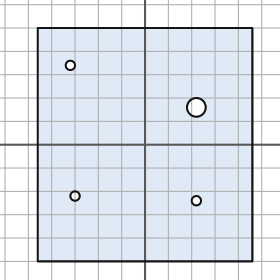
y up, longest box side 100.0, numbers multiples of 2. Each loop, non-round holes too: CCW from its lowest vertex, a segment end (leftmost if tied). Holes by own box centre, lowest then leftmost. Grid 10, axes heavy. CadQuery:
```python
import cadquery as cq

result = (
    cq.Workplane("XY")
    .moveTo(-46.0, -50.0)
    .lineTo(46.0, -50.0)
    .lineTo(46.0, 50.0)
    .lineTo(-46.0, 50.0)
    .close()
    .moveTo(22.0, -24.0)
    .circle(2.0)
    .moveTo(-30.0, -22.0)
    .circle(2.0)
    .moveTo(22.0, 16.0)
    .circle(4.0)
    .moveTo(-32.0, 34.0)
    .circle(2.0)
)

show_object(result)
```